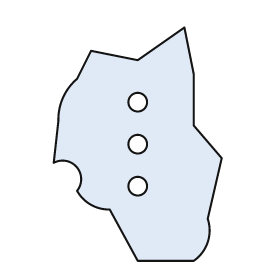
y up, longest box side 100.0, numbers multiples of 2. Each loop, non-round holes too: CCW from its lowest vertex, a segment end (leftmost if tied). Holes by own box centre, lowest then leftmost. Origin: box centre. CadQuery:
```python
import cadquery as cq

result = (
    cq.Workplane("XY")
    .moveTo(0.0, -50.0)
    .lineTo(24.0, -50.0)
    .threePointArc((30.0, -42.0), (30.0, -32.0))
    .lineTo(36.0, -6.0)
    .lineTo(24.0, 8.0)
    .lineTo(24.0, 30.0)
    .lineTo(20.0, 50.0)
    .lineTo(0.0, 36.0)
    .lineTo(-20.0, 40.0)
    .lineTo(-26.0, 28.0)
    .threePointArc((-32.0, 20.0), (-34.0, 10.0))
    .lineTo(-36.0, -8.0)
    .threePointArc((-26.0, -10.0), (-26.0, -20.0))
    .threePointArc((-20.0, -26.0), (-12.0, -28.0))
    .close()
    .moveTo(0.0, -18.0)
    .circle(4.0)
    .moveTo(0.0, 0.0)
    .circle(4.0)
    .moveTo(0.0, 18.0)
    .circle(4.0)
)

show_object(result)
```